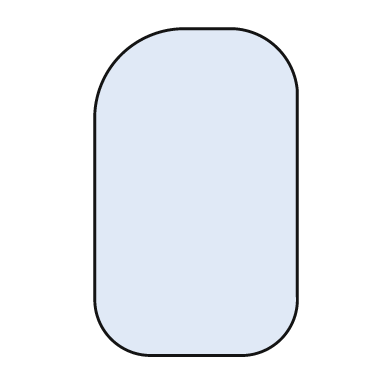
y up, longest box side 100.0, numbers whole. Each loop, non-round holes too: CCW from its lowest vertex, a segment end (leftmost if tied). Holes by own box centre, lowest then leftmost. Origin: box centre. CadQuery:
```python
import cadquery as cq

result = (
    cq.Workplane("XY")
    .moveTo(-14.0, -50.0)
    .lineTo(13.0, -50.0)
    .threePointArc((26.0, -45.0), (31.0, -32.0))
    .lineTo(31.0, 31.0)
    .threePointArc((25.0, 44.0), (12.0, 50.0))
    .lineTo(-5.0, 50.0)
    .threePointArc((-23.0, 42.0), (-31.0, 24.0))
    .lineTo(-31.0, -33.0)
    .threePointArc((-26.0, -45.0), (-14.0, -50.0))
    .close()
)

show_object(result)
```